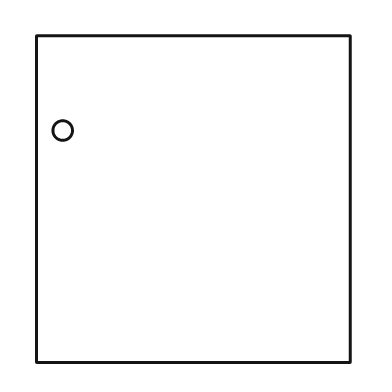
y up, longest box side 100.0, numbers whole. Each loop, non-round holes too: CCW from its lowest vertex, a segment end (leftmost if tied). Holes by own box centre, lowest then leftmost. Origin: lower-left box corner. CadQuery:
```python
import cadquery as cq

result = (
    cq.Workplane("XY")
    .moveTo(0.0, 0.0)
    .lineTo(96.0, 0.0)
    .lineTo(96.0, 100.0)
    .lineTo(0.0, 100.0)
    .close()
    .moveTo(8.0, 71.0)
    .circle(3.0)
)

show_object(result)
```